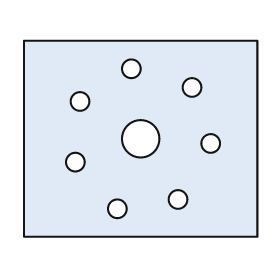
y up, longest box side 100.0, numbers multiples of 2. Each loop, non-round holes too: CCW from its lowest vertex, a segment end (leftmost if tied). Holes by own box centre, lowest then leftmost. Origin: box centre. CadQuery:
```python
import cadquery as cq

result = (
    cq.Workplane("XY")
    .moveTo(-50.0, -42.0)
    .lineTo(50.0, -42.0)
    .lineTo(50.0, 42.0)
    .lineTo(-50.0, 42.0)
    .close()
    .moveTo(-10.0, -30.0)
    .circle(4.0)
    .moveTo(16.0, -26.0)
    .circle(4.0)
    .moveTo(-28.0, -10.0)
    .circle(4.0)
    .moveTo(30.0, -2.0)
    .circle(4.0)
    .moveTo(0.0, 0.0)
    .circle(8.0)
    .moveTo(-26.0, 16.0)
    .circle(4.0)
    .moveTo(22.0, 22.0)
    .circle(4.0)
    .moveTo(-4.0, 30.0)
    .circle(4.0)
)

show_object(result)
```